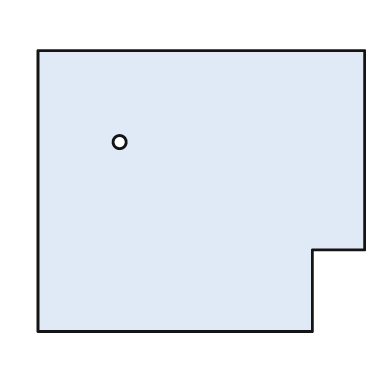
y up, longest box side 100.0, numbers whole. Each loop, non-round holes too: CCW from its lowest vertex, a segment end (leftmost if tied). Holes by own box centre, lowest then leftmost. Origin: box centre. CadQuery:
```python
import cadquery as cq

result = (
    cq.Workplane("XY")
    .moveTo(-50.0, -43.0)
    .lineTo(34.0, -43.0)
    .lineTo(34.0, -18.0)
    .lineTo(50.0, -18.0)
    .lineTo(50.0, 43.0)
    .lineTo(-50.0, 43.0)
    .close()
    .moveTo(-25.0, 15.0)
    .circle(2.0)
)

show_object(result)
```